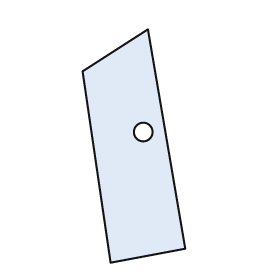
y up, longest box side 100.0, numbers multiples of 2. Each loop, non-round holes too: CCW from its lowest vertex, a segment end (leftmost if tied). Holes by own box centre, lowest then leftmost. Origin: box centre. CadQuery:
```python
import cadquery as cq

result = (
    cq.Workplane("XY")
    .moveTo(-10.0, -50.0)
    .lineTo(22.0, -44.0)
    .lineTo(6.0, 50.0)
    .lineTo(-22.0, 32.0)
    .close()
    .moveTo(4.0, 6.0)
    .circle(4.0)
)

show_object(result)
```